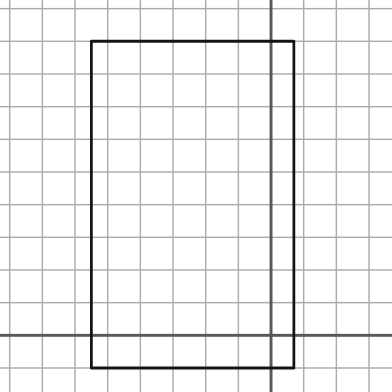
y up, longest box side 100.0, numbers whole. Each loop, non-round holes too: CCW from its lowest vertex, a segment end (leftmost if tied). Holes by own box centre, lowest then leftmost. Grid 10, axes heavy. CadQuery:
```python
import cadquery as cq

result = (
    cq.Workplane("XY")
    .moveTo(-55.0, -10.0)
    .lineTo(7.0, -10.0)
    .lineTo(7.0, 90.0)
    .lineTo(-55.0, 90.0)
    .close()
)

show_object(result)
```